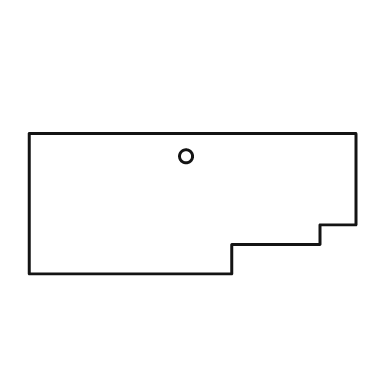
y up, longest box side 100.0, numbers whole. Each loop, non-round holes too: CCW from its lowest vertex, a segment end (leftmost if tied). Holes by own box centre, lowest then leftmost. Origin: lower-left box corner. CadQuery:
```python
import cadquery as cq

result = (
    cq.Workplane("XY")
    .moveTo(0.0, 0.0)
    .lineTo(62.0, 0.0)
    .lineTo(62.0, 9.0)
    .lineTo(89.0, 9.0)
    .lineTo(89.0, 15.0)
    .lineTo(100.0, 15.0)
    .lineTo(100.0, 43.0)
    .lineTo(0.0, 43.0)
    .close()
    .moveTo(48.0, 36.0)
    .circle(2.0)
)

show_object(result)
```